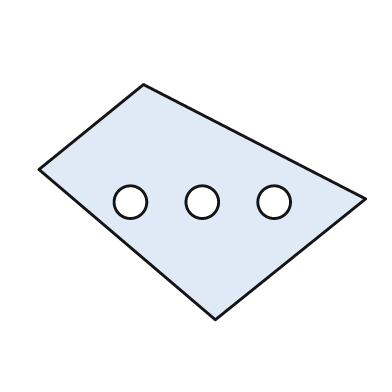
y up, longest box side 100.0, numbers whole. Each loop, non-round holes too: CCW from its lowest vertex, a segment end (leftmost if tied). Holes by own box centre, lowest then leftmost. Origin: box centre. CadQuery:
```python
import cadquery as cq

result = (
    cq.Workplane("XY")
    .moveTo(4.0, -36.0)
    .lineTo(50.0, 1.0)
    .lineTo(-18.0, 36.0)
    .lineTo(-50.0, 10.0)
    .close()
    .moveTo(-22.0, 0.0)
    .circle(5.0)
    .moveTo(0.0, 0.0)
    .circle(5.0)
    .moveTo(22.0, 0.0)
    .circle(5.0)
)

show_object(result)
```